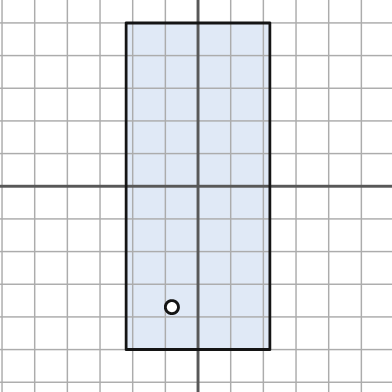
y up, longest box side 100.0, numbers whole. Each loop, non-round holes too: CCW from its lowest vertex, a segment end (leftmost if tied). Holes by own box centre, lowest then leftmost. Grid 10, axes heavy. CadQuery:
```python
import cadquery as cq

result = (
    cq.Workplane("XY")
    .moveTo(-22.0, -50.0)
    .lineTo(22.0, -50.0)
    .lineTo(22.0, 50.0)
    .lineTo(-22.0, 50.0)
    .close()
    .moveTo(-8.0, -37.0)
    .circle(2.0)
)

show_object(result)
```